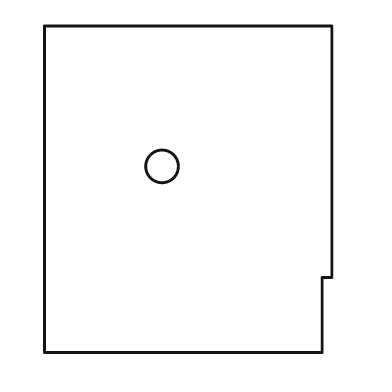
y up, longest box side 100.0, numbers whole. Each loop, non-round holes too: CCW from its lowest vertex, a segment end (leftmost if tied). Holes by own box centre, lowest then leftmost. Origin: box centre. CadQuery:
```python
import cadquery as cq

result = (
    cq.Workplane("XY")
    .moveTo(-44.0, -50.0)
    .lineTo(41.0, -50.0)
    .lineTo(41.0, -27.0)
    .lineTo(44.0, -27.0)
    .lineTo(44.0, 50.0)
    .lineTo(-44.0, 50.0)
    .close()
    .moveTo(-8.0, 7.0)
    .circle(5.0)
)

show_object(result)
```